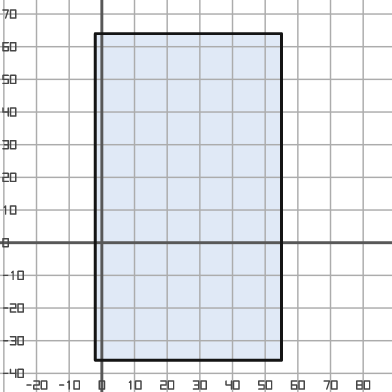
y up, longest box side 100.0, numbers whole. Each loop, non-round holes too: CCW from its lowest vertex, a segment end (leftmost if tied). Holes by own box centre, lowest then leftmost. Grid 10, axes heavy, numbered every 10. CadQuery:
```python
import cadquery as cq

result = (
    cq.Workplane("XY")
    .moveTo(-2.0, -36.0)
    .lineTo(55.0, -36.0)
    .lineTo(55.0, 64.0)
    .lineTo(-2.0, 64.0)
    .close()
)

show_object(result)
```